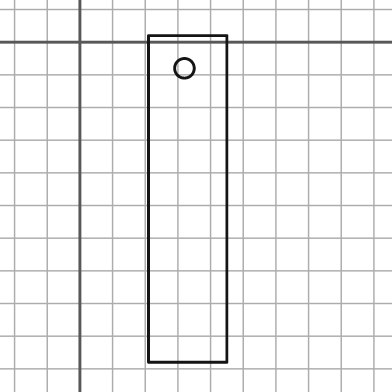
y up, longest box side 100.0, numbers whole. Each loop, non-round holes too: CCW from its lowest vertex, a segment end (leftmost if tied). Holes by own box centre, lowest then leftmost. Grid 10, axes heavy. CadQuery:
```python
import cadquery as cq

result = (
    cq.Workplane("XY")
    .moveTo(21.0, -98.0)
    .lineTo(45.0, -98.0)
    .lineTo(45.0, 2.0)
    .lineTo(21.0, 2.0)
    .close()
    .moveTo(32.0, -8.0)
    .circle(3.0)
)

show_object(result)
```